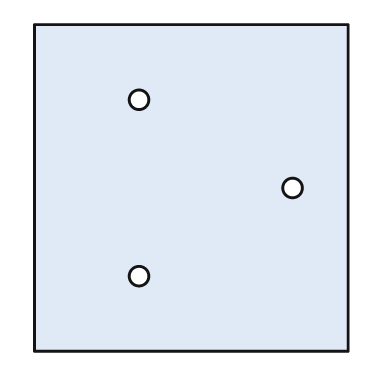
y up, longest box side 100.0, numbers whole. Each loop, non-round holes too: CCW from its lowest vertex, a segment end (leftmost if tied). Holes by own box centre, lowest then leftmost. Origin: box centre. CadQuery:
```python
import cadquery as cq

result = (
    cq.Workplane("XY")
    .moveTo(-48.0, -50.0)
    .lineTo(48.0, -50.0)
    .lineTo(48.0, 50.0)
    .lineTo(-48.0, 50.0)
    .close()
    .moveTo(-16.0, -27.0)
    .circle(3.0)
    .moveTo(31.0, 0.0)
    .circle(3.0)
    .moveTo(-16.0, 27.0)
    .circle(3.0)
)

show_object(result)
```